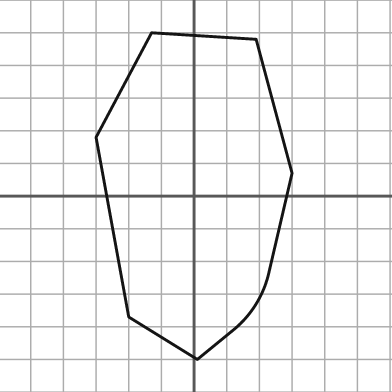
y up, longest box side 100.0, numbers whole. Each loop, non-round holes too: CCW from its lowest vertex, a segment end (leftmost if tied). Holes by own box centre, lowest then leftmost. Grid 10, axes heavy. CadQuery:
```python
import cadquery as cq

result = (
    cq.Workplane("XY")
    .moveTo(1.0, -50.0)
    .lineTo(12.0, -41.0)
    .threePointArc((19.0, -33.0), (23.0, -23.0))
    .lineTo(30.0, 7.0)
    .lineTo(19.0, 48.0)
    .lineTo(-13.0, 50.0)
    .lineTo(-30.0, 18.0)
    .lineTo(-20.0, -37.0)
    .close()
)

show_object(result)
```